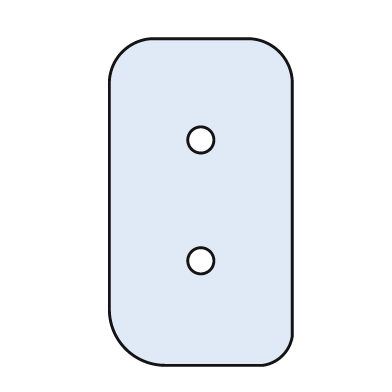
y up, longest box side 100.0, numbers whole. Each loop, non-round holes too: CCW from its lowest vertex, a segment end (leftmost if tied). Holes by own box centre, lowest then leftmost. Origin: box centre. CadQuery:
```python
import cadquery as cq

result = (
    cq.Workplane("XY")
    .moveTo(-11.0, -50.0)
    .lineTo(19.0, -50.0)
    .threePointArc((25.0, -47.0), (28.0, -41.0))
    .lineTo(28.0, 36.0)
    .threePointArc((24.0, 46.0), (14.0, 50.0))
    .lineTo(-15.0, 50.0)
    .threePointArc((-24.0, 46.0), (-28.0, 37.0))
    .lineTo(-28.0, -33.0)
    .threePointArc((-23.0, -45.0), (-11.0, -50.0))
    .close()
    .moveTo(0.0, -18.0)
    .circle(4.0)
    .moveTo(0.0, 19.0)
    .circle(4.0)
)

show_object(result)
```